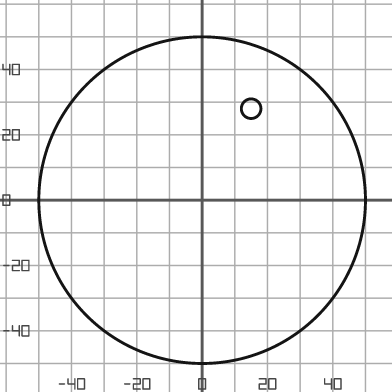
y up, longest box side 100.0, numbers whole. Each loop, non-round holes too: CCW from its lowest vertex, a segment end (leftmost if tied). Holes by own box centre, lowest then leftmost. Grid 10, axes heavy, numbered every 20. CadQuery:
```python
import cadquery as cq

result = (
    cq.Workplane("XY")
    .moveTo(0.0, 0.0)
    .circle(50.0)
    .moveTo(15.0, 28.0)
    .circle(3.0)
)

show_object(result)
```